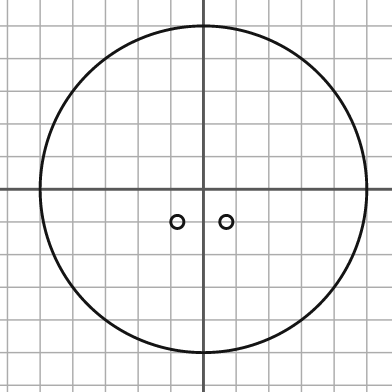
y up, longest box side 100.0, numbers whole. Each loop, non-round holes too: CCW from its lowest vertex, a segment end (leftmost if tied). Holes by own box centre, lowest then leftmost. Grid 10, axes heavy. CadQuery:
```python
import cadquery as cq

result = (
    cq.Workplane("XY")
    .moveTo(0.0, 0.0)
    .circle(50.0)
    .moveTo(-8.0, -10.0)
    .circle(2.0)
    .moveTo(7.0, -10.0)
    .circle(2.0)
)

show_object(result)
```